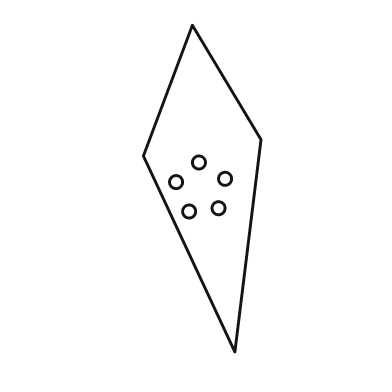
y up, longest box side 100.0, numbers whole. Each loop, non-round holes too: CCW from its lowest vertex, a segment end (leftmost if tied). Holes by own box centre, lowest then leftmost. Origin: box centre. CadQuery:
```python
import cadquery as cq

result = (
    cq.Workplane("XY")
    .moveTo(10.0, -50.0)
    .lineTo(18.0, 15.0)
    .lineTo(-3.0, 50.0)
    .lineTo(-18.0, 10.0)
    .close()
    .moveTo(-4.0, -7.0)
    .circle(2.0)
    .moveTo(5.0, -6.0)
    .circle(2.0)
    .moveTo(-8.0, 2.0)
    .circle(2.0)
    .moveTo(7.0, 3.0)
    .circle(2.0)
    .moveTo(-1.0, 8.0)
    .circle(2.0)
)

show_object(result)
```